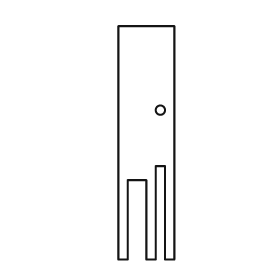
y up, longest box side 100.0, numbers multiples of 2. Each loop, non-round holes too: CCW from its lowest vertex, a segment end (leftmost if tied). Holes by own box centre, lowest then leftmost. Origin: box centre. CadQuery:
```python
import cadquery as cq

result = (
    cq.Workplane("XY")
    .moveTo(-12.0, -50.0)
    .lineTo(-8.0, -50.0)
    .lineTo(-8.0, -16.0)
    .lineTo(0.0, -16.0)
    .lineTo(0.0, -50.0)
    .lineTo(4.0, -50.0)
    .lineTo(4.0, -10.0)
    .lineTo(8.0, -10.0)
    .lineTo(8.0, -50.0)
    .lineTo(12.0, -50.0)
    .lineTo(12.0, 50.0)
    .lineTo(-12.0, 50.0)
    .close()
    .moveTo(6.0, 14.0)
    .circle(2.0)
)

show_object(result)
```